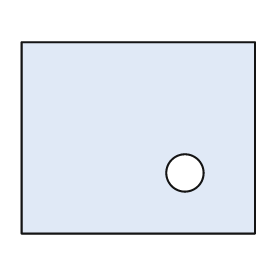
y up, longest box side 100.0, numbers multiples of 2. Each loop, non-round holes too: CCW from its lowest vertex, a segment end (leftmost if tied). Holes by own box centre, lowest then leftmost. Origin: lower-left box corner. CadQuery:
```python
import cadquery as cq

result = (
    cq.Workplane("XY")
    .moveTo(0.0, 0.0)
    .lineTo(100.0, 0.0)
    .lineTo(100.0, 82.0)
    .lineTo(0.0, 82.0)
    .close()
    .moveTo(70.0, 26.0)
    .circle(8.0)
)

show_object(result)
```